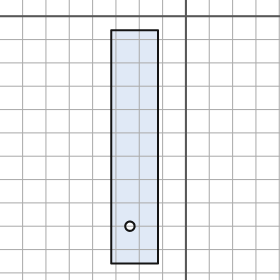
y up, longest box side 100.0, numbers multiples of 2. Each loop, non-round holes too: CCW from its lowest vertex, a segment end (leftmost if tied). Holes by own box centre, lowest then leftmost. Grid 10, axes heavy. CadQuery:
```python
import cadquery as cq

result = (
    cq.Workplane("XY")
    .moveTo(-32.0, -106.0)
    .lineTo(-12.0, -106.0)
    .lineTo(-12.0, -6.0)
    .lineTo(-32.0, -6.0)
    .close()
    .moveTo(-24.0, -90.0)
    .circle(2.0)
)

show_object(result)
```